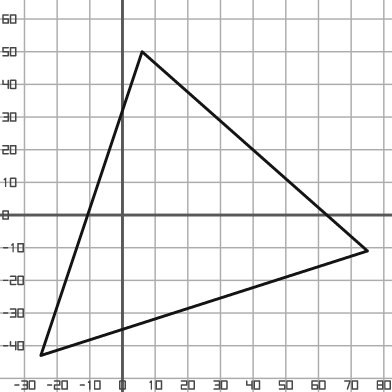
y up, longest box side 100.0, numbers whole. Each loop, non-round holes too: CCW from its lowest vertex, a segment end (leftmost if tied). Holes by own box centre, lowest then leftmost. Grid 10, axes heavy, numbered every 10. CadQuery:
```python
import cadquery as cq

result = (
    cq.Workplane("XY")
    .moveTo(-25.0, -43.0)
    .lineTo(75.0, -11.0)
    .lineTo(6.0, 50.0)
    .close()
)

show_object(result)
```